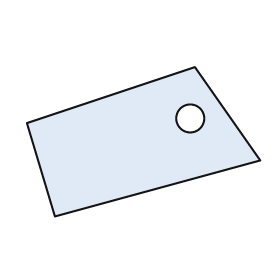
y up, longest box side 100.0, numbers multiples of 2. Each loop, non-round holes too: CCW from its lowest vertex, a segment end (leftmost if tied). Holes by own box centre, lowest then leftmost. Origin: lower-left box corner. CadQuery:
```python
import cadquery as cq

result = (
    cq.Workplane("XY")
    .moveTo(12.0, 0.0)
    .lineTo(100.0, 24.0)
    .lineTo(72.0, 64.0)
    .lineTo(0.0, 40.0)
    .close()
    .moveTo(70.0, 42.0)
    .circle(6.0)
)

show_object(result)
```